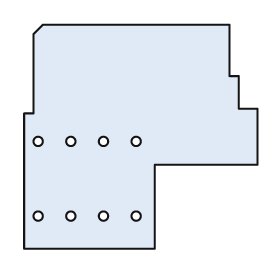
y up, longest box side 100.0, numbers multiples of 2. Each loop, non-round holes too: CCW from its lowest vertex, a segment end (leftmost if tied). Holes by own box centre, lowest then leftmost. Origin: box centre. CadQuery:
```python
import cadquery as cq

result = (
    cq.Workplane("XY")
    .moveTo(-50.0, -48.0)
    .lineTo(6.0, -48.0)
    .lineTo(6.0, -12.0)
    .lineTo(50.0, -12.0)
    .lineTo(50.0, 12.0)
    .lineTo(42.0, 12.0)
    .lineTo(42.0, 26.0)
    .lineTo(38.0, 26.0)
    .lineTo(38.0, 48.0)
    .lineTo(-42.0, 48.0)
    .lineTo(-46.0, 44.0)
    .lineTo(-46.0, 10.0)
    .lineTo(-50.0, 10.0)
    .close()
    .moveTo(-44.0, -34.0)
    .circle(2.0)
    .moveTo(-30.0, -34.0)
    .circle(2.0)
    .moveTo(-16.0, -34.0)
    .circle(2.0)
    .moveTo(-2.0, -34.0)
    .circle(2.0)
    .moveTo(-44.0, -2.0)
    .circle(2.0)
    .moveTo(-30.0, -2.0)
    .circle(2.0)
    .moveTo(-16.0, -2.0)
    .circle(2.0)
    .moveTo(-2.0, -2.0)
    .circle(2.0)
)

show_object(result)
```